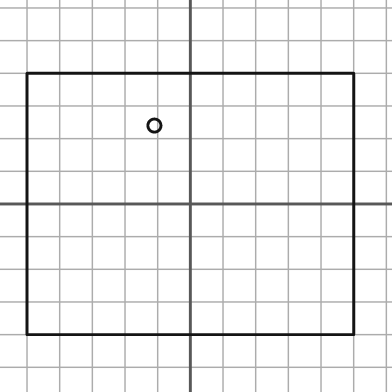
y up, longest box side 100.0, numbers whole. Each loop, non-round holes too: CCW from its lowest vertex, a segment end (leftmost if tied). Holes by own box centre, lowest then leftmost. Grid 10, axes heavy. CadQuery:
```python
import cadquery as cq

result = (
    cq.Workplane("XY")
    .moveTo(-50.0, -40.0)
    .lineTo(50.0, -40.0)
    .lineTo(50.0, 40.0)
    .lineTo(-50.0, 40.0)
    .close()
    .moveTo(-11.0, 24.0)
    .circle(2.0)
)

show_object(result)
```